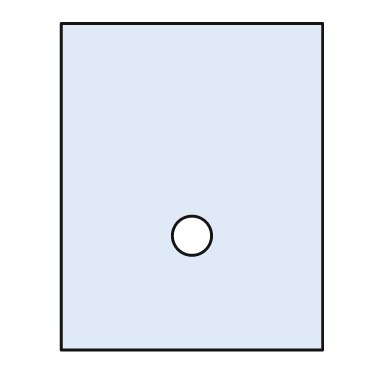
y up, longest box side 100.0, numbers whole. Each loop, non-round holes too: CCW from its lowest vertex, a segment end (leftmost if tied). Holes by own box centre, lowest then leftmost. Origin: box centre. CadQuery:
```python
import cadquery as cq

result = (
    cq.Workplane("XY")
    .moveTo(-40.0, -50.0)
    .lineTo(40.0, -50.0)
    .lineTo(40.0, 50.0)
    .lineTo(-40.0, 50.0)
    .close()
    .moveTo(0.0, -15.0)
    .circle(6.0)
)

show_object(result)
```